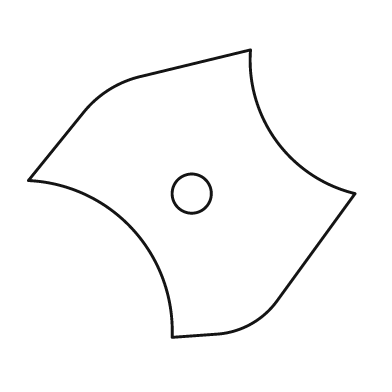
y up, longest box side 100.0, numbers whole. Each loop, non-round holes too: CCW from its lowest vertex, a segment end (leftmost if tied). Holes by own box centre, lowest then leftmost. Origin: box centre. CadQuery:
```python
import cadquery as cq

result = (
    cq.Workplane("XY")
    .moveTo(-6.0, -44.0)
    .lineTo(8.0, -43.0)
    .threePointArc((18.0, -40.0), (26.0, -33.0))
    .lineTo(50.0, 0.0)
    .threePointArc((26.0, 16.0), (18.0, 44.0))
    .lineTo(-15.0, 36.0)
    .threePointArc((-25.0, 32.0), (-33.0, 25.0))
    .lineTo(-50.0, 4.0)
    .threePointArc((-18.0, -11.0), (-6.0, -44.0))
    .close()
    .moveTo(0.0, 0.0)
    .circle(6.0)
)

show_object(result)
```